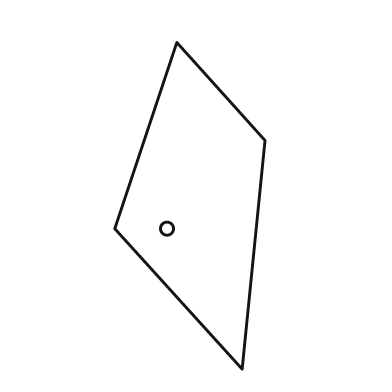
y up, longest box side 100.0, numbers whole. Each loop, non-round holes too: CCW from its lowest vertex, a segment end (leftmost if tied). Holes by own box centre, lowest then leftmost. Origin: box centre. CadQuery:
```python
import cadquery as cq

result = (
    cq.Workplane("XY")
    .moveTo(16.0, -50.0)
    .lineTo(23.0, 20.0)
    .lineTo(-4.0, 50.0)
    .lineTo(-23.0, -7.0)
    .close()
    .moveTo(-7.0, -7.0)
    .circle(2.0)
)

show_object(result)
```